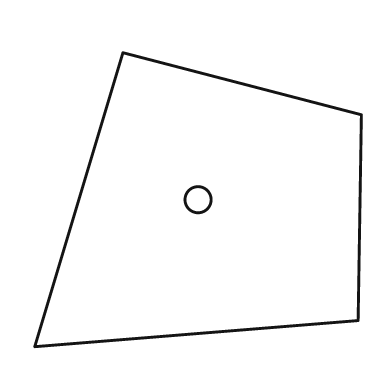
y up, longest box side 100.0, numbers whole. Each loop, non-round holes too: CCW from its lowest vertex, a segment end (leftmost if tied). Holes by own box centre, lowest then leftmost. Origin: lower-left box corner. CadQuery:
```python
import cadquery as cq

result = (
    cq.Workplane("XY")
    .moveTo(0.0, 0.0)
    .lineTo(99.0, 8.0)
    .lineTo(100.0, 71.0)
    .lineTo(27.0, 90.0)
    .close()
    .moveTo(50.0, 45.0)
    .circle(4.0)
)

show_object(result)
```